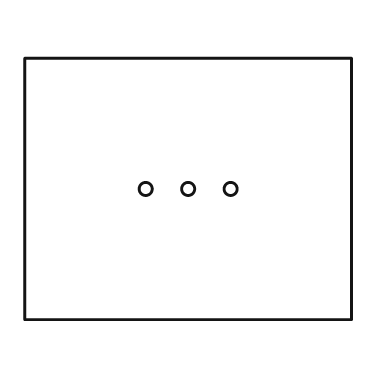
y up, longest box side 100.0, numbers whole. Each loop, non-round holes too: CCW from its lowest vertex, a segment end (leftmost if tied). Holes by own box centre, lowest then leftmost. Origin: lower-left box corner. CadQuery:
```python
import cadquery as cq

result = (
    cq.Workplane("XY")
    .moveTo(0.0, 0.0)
    .lineTo(100.0, 0.0)
    .lineTo(100.0, 80.0)
    .lineTo(0.0, 80.0)
    .close()
    .moveTo(37.0, 40.0)
    .circle(2.0)
    .moveTo(50.0, 40.0)
    .circle(2.0)
    .moveTo(63.0, 40.0)
    .circle(2.0)
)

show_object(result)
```